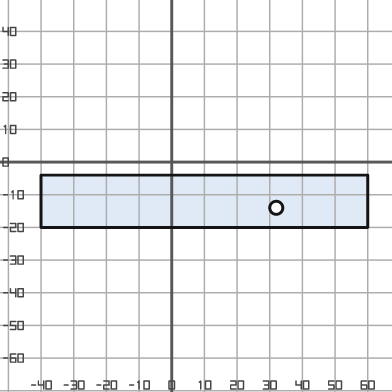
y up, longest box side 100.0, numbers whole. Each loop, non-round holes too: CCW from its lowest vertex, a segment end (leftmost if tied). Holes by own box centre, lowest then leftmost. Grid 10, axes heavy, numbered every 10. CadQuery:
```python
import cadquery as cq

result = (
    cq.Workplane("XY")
    .moveTo(-40.0, -20.0)
    .lineTo(60.0, -20.0)
    .lineTo(60.0, -4.0)
    .lineTo(-40.0, -4.0)
    .close()
    .moveTo(32.0, -14.0)
    .circle(2.0)
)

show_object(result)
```